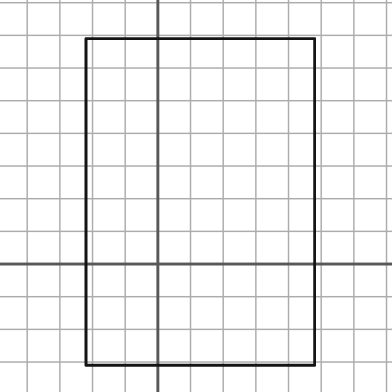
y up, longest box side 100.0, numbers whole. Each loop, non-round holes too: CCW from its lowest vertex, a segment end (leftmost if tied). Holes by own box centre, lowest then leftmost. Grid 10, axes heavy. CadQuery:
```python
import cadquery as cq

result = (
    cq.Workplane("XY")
    .moveTo(-22.0, -31.0)
    .lineTo(48.0, -31.0)
    .lineTo(48.0, 69.0)
    .lineTo(-22.0, 69.0)
    .close()
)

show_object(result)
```